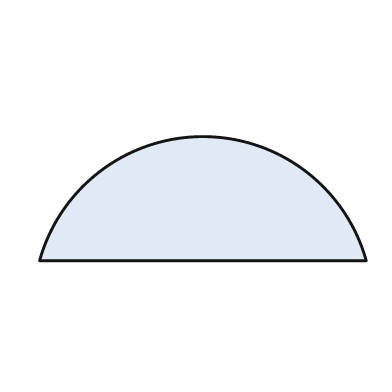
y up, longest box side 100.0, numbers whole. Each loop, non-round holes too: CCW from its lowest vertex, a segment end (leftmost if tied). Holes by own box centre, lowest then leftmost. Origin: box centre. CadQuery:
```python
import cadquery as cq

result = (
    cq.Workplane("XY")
    .moveTo(-50.0, -19.0)
    .lineTo(50.0, -19.0)
    .threePointArc((0.0, 19.0), (-50.0, -19.0))
    .close()
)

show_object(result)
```